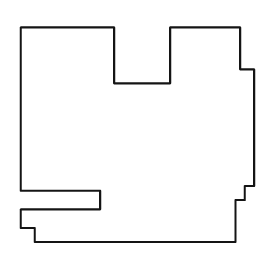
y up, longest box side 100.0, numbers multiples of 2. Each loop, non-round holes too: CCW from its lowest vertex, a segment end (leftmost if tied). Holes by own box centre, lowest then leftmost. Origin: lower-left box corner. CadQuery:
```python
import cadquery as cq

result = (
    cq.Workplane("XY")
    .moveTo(6.0, 0.0)
    .lineTo(92.0, 0.0)
    .lineTo(92.0, 18.0)
    .lineTo(96.0, 18.0)
    .lineTo(96.0, 24.0)
    .lineTo(100.0, 24.0)
    .lineTo(100.0, 74.0)
    .lineTo(94.0, 74.0)
    .lineTo(94.0, 92.0)
    .lineTo(64.0, 92.0)
    .lineTo(64.0, 68.0)
    .lineTo(40.0, 68.0)
    .lineTo(40.0, 92.0)
    .lineTo(0.0, 92.0)
    .lineTo(0.0, 22.0)
    .lineTo(34.0, 22.0)
    .lineTo(34.0, 14.0)
    .lineTo(0.0, 14.0)
    .lineTo(0.0, 6.0)
    .lineTo(6.0, 6.0)
    .close()
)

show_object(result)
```